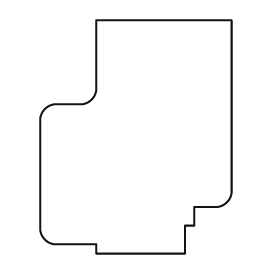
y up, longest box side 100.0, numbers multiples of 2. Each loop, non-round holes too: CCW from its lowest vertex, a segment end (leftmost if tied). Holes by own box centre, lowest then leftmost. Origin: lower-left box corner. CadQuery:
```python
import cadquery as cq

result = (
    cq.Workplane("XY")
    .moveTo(24.0, 0.0)
    .lineTo(62.0, 0.0)
    .lineTo(62.0, 12.0)
    .lineTo(66.0, 12.0)
    .lineTo(66.0, 20.0)
    .lineTo(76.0, 20.0)
    .threePointArc((80.0, 22.0), (82.0, 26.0))
    .lineTo(82.0, 100.0)
    .lineTo(24.0, 100.0)
    .lineTo(24.0, 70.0)
    .threePointArc((22.0, 66.0), (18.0, 64.0))
    .lineTo(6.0, 64.0)
    .threePointArc((2.0, 62.0), (0.0, 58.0))
    .lineTo(0.0, 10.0)
    .threePointArc((2.0, 6.0), (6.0, 4.0))
    .lineTo(24.0, 4.0)
    .close()
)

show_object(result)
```